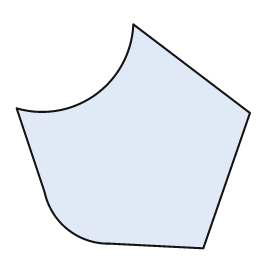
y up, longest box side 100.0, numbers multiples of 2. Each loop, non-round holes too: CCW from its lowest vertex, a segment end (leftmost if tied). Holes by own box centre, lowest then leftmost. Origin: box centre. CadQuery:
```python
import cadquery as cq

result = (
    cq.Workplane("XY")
    .moveTo(30.0, -48.0)
    .lineTo(50.0, 10.0)
    .lineTo(0.0, 48.0)
    .threePointArc((-16.0, 18.0), (-50.0, 12.0))
    .lineTo(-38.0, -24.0)
    .threePointArc((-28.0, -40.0), (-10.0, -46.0))
    .close()
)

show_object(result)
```